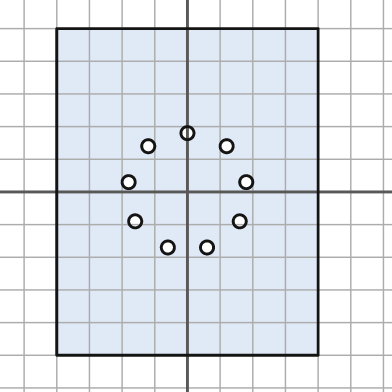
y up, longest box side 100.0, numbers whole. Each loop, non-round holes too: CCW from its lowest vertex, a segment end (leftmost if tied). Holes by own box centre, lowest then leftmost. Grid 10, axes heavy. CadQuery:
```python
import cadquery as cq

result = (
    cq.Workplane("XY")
    .moveTo(-40.0, -50.0)
    .lineTo(40.0, -50.0)
    .lineTo(40.0, 50.0)
    .lineTo(-40.0, 50.0)
    .close()
    .moveTo(-6.0, -17.0)
    .circle(2.0)
    .moveTo(6.0, -17.0)
    .circle(2.0)
    .moveTo(-16.0, -9.0)
    .circle(2.0)
    .moveTo(16.0, -9.0)
    .circle(2.0)
    .moveTo(-18.0, 3.0)
    .circle(2.0)
    .moveTo(18.0, 3.0)
    .circle(2.0)
    .moveTo(-12.0, 14.0)
    .circle(2.0)
    .moveTo(12.0, 14.0)
    .circle(2.0)
    .moveTo(0.0, 18.0)
    .circle(2.0)
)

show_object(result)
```